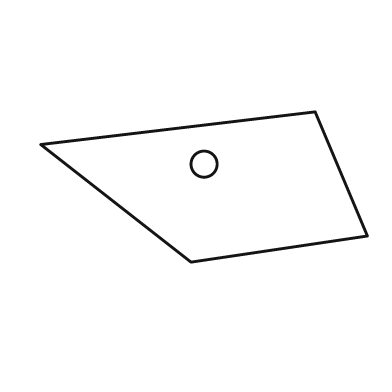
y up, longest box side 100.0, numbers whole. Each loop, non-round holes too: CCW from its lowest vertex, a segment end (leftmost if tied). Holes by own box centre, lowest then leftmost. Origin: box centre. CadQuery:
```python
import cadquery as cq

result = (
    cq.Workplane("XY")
    .moveTo(-4.0, -23.0)
    .lineTo(50.0, -15.0)
    .lineTo(34.0, 23.0)
    .lineTo(-50.0, 13.0)
    .close()
    .moveTo(0.0, 7.0)
    .circle(4.0)
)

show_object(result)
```